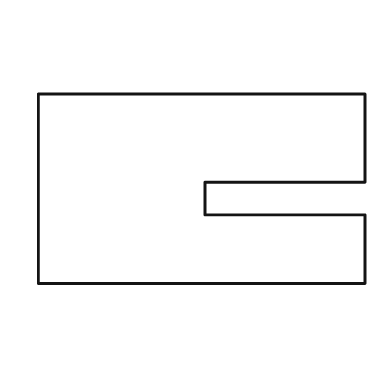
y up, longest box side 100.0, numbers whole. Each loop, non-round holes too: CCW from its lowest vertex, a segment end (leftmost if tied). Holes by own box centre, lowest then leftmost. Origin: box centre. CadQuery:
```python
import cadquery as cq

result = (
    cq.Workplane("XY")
    .moveTo(-50.0, -29.0)
    .lineTo(50.0, -29.0)
    .lineTo(50.0, -8.0)
    .lineTo(1.0, -8.0)
    .lineTo(1.0, 2.0)
    .lineTo(50.0, 2.0)
    .lineTo(50.0, 29.0)
    .lineTo(-50.0, 29.0)
    .close()
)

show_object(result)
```